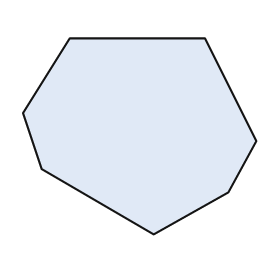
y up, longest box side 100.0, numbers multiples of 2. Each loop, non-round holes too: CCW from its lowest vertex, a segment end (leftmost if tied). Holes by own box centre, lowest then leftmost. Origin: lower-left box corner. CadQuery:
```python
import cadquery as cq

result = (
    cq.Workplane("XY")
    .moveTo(56.0, 0.0)
    .lineTo(88.0, 18.0)
    .lineTo(100.0, 40.0)
    .lineTo(78.0, 84.0)
    .lineTo(20.0, 84.0)
    .lineTo(0.0, 52.0)
    .lineTo(8.0, 28.0)
    .close()
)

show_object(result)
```